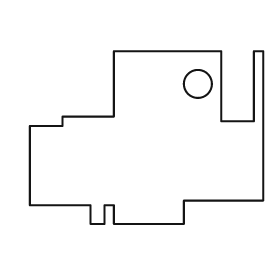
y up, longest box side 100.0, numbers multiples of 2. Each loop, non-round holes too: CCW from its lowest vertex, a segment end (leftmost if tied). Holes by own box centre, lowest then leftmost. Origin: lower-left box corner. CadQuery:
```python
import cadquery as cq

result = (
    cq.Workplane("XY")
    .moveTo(26.0, 0.0)
    .lineTo(32.0, 0.0)
    .lineTo(32.0, 8.0)
    .lineTo(36.0, 8.0)
    .lineTo(36.0, 0.0)
    .lineTo(66.0, 0.0)
    .lineTo(66.0, 10.0)
    .lineTo(100.0, 10.0)
    .lineTo(100.0, 74.0)
    .lineTo(96.0, 74.0)
    .lineTo(96.0, 44.0)
    .lineTo(82.0, 44.0)
    .lineTo(82.0, 74.0)
    .lineTo(36.0, 74.0)
    .lineTo(36.0, 46.0)
    .lineTo(14.0, 46.0)
    .lineTo(14.0, 42.0)
    .lineTo(0.0, 42.0)
    .lineTo(0.0, 8.0)
    .lineTo(26.0, 8.0)
    .close()
    .moveTo(72.0, 60.0)
    .circle(6.0)
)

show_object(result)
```